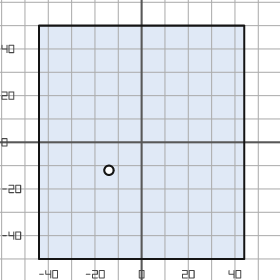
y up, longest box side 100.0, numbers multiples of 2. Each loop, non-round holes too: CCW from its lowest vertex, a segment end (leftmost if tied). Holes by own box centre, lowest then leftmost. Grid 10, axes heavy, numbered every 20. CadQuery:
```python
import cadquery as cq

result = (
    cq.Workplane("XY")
    .moveTo(-44.0, -50.0)
    .lineTo(44.0, -50.0)
    .lineTo(44.0, 50.0)
    .lineTo(-44.0, 50.0)
    .close()
    .moveTo(-14.0, -12.0)
    .circle(2.0)
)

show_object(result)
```